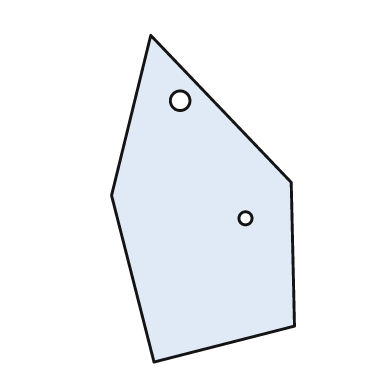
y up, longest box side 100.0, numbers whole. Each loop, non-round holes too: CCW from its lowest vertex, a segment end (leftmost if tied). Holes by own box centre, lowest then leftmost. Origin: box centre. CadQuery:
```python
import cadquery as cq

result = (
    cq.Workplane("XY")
    .moveTo(-15.0, -50.0)
    .lineTo(28.0, -39.0)
    .lineTo(27.0, 5.0)
    .lineTo(-16.0, 50.0)
    .lineTo(-28.0, 1.0)
    .close()
    .moveTo(13.0, -6.0)
    .circle(2.0)
    .moveTo(-7.0, 30.0)
    .circle(3.0)
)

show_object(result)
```